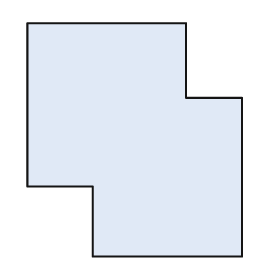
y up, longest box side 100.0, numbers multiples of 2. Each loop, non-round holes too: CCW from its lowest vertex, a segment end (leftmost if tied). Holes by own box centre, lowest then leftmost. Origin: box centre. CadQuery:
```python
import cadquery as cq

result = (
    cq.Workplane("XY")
    .moveTo(-18.0, -50.0)
    .lineTo(46.0, -50.0)
    .lineTo(46.0, 18.0)
    .lineTo(22.0, 18.0)
    .lineTo(22.0, 50.0)
    .lineTo(-46.0, 50.0)
    .lineTo(-46.0, -20.0)
    .lineTo(-18.0, -20.0)
    .close()
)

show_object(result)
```